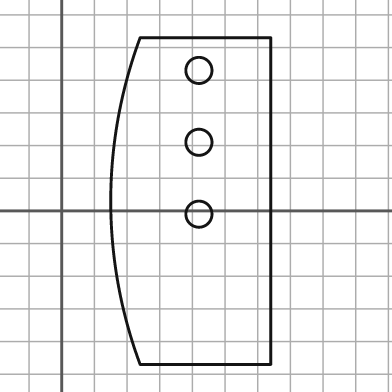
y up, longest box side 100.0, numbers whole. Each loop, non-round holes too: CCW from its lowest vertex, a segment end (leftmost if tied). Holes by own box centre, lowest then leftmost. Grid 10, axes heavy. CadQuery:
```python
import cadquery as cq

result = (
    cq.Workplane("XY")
    .moveTo(24.0, -47.0)
    .lineTo(64.0, -47.0)
    .lineTo(64.0, 53.0)
    .lineTo(24.0, 53.0)
    .threePointArc((15.0, 3.0), (24.0, -47.0))
    .close()
    .moveTo(42.0, -1.0)
    .circle(4.0)
    .moveTo(42.0, 21.0)
    .circle(4.0)
    .moveTo(42.0, 43.0)
    .circle(4.0)
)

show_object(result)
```